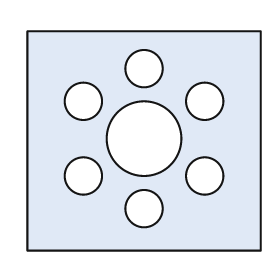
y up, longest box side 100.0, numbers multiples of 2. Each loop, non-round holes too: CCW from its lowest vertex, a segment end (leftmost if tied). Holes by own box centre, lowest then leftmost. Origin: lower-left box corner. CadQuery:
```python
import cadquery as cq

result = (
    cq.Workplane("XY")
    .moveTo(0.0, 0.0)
    .lineTo(100.0, 0.0)
    .lineTo(100.0, 94.0)
    .lineTo(0.0, 94.0)
    .close()
    .moveTo(50.0, 18.0)
    .circle(8.0)
    .moveTo(24.0, 32.0)
    .circle(8.0)
    .moveTo(76.0, 32.0)
    .circle(8.0)
    .moveTo(50.0, 48.0)
    .circle(16.0)
    .moveTo(24.0, 64.0)
    .circle(8.0)
    .moveTo(76.0, 64.0)
    .circle(8.0)
    .moveTo(50.0, 78.0)
    .circle(8.0)
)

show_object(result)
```